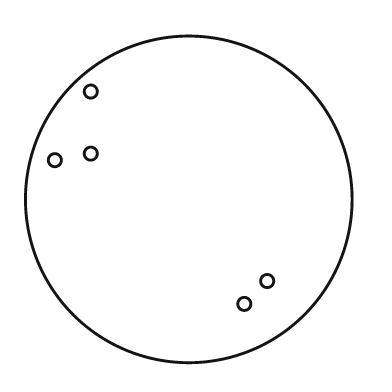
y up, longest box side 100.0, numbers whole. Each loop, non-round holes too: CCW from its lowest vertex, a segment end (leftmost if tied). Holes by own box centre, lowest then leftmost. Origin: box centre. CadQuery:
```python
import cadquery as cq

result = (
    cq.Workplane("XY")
    .moveTo(0.0, 0.0)
    .circle(50.0)
    .moveTo(17.0, -32.0)
    .circle(2.0)
    .moveTo(24.0, -25.0)
    .circle(2.0)
    .moveTo(-41.0, 12.0)
    .circle(2.0)
    .moveTo(-30.0, 14.0)
    .circle(2.0)
    .moveTo(-30.0, 33.0)
    .circle(2.0)
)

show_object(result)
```